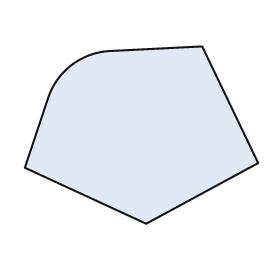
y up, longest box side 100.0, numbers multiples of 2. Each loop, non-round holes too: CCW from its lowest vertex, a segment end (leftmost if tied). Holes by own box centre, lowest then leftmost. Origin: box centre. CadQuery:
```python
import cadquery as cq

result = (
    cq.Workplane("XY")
    .moveTo(2.0, -38.0)
    .lineTo(50.0, -12.0)
    .lineTo(26.0, 38.0)
    .lineTo(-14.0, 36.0)
    .threePointArc((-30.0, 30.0), (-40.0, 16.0))
    .lineTo(-50.0, -14.0)
    .close()
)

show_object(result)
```